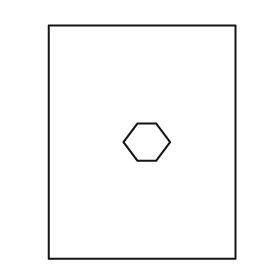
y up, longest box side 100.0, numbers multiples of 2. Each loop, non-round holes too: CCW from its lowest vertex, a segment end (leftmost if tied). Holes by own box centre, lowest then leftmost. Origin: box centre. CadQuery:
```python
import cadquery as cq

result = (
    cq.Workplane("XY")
    .moveTo(-40.0, -50.0)
    .lineTo(40.0, -50.0)
    .lineTo(40.0, 50.0)
    .lineTo(-40.0, 50.0)
    .close()
    .moveTo(-2.0, -8.0)
    .lineTo(6.0, -8.0)
    .lineTo(12.0, 0.0)
    .lineTo(6.0, 8.0)
    .lineTo(-2.0, 8.0)
    .lineTo(-8.0, 0.0)
    .close()
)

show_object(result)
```